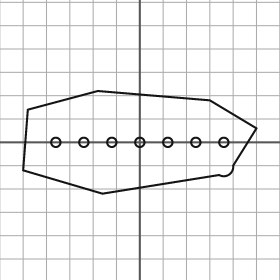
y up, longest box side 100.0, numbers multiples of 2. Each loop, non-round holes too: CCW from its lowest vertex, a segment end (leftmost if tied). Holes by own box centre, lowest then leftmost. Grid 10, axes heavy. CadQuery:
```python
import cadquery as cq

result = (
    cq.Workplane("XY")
    .moveTo(-16.0, -22.0)
    .lineTo(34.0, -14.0)
    .threePointArc((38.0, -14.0), (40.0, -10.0))
    .lineTo(50.0, 6.0)
    .lineTo(30.0, 18.0)
    .lineTo(-18.0, 22.0)
    .lineTo(-48.0, 14.0)
    .lineTo(-50.0, -12.0)
    .close()
    .moveTo(-36.0, 0.0)
    .circle(2.0)
    .moveTo(-24.0, 0.0)
    .circle(2.0)
    .moveTo(-12.0, 0.0)
    .circle(2.0)
    .moveTo(0.0, 0.0)
    .circle(2.0)
    .moveTo(12.0, 0.0)
    .circle(2.0)
    .moveTo(24.0, 0.0)
    .circle(2.0)
    .moveTo(36.0, 0.0)
    .circle(2.0)
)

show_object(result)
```